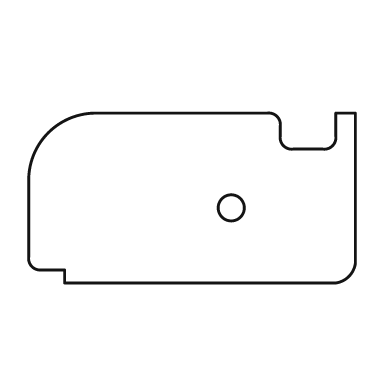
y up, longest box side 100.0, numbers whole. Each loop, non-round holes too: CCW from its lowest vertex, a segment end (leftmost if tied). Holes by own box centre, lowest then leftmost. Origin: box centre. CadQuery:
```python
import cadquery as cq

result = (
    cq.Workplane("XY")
    .moveTo(-39.0, -26.0)
    .lineTo(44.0, -26.0)
    .threePointArc((48.0, -24.0), (50.0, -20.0))
    .lineTo(50.0, 26.0)
    .lineTo(44.0, 26.0)
    .lineTo(44.0, 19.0)
    .threePointArc((43.0, 16.0), (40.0, 15.0))
    .lineTo(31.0, 15.0)
    .threePointArc((28.0, 16.0), (27.0, 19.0))
    .lineTo(27.0, 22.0)
    .threePointArc((26.0, 25.0), (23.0, 26.0))
    .lineTo(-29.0, 26.0)
    .threePointArc((-44.0, 20.0), (-50.0, 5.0))
    .lineTo(-50.0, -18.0)
    .threePointArc((-49.0, -21.0), (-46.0, -22.0))
    .lineTo(-39.0, -22.0)
    .close()
    .moveTo(12.0, -3.0)
    .circle(4.0)
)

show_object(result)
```